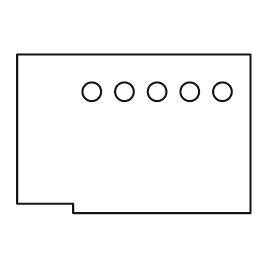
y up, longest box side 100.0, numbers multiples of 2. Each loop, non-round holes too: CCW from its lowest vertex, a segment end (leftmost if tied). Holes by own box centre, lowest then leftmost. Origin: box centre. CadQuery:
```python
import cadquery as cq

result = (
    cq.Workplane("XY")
    .moveTo(-26.0, -34.0)
    .lineTo(50.0, -34.0)
    .lineTo(50.0, 34.0)
    .lineTo(-50.0, 34.0)
    .lineTo(-50.0, -30.0)
    .lineTo(-26.0, -30.0)
    .close()
    .moveTo(-18.0, 18.0)
    .circle(4.0)
    .moveTo(-4.0, 18.0)
    .circle(4.0)
    .moveTo(10.0, 18.0)
    .circle(4.0)
    .moveTo(24.0, 18.0)
    .circle(4.0)
    .moveTo(38.0, 18.0)
    .circle(4.0)
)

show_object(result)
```